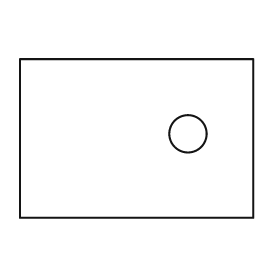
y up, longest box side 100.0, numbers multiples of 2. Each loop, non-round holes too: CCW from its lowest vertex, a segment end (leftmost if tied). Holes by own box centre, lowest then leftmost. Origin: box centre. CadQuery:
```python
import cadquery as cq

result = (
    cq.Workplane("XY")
    .moveTo(-50.0, -34.0)
    .lineTo(50.0, -34.0)
    .lineTo(50.0, 34.0)
    .lineTo(-50.0, 34.0)
    .close()
    .moveTo(22.0, 2.0)
    .circle(8.0)
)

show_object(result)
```